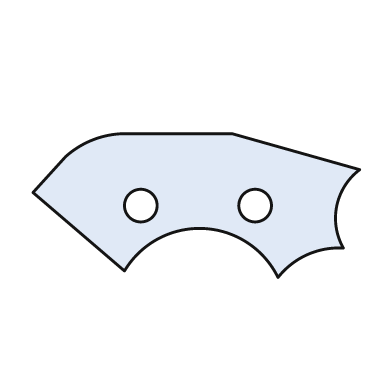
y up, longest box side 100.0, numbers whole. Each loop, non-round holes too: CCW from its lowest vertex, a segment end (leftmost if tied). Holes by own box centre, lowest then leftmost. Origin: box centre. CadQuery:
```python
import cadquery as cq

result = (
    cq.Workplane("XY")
    .moveTo(25.0, -22.0)
    .threePointArc((34.0, -15.0), (45.0, -13.0))
    .threePointArc((43.0, 0.0), (50.0, 11.0))
    .lineTo(11.0, 22.0)
    .lineTo(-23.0, 22.0)
    .threePointArc((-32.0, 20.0), (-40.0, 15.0))
    .lineTo(-50.0, 4.0)
    .lineTo(-22.0, -20.0)
    .threePointArc((2.0, -7.0), (25.0, -22.0))
    .close()
    .moveTo(-17.0, 0.0)
    .circle(5.0)
    .moveTo(18.0, 0.0)
    .circle(5.0)
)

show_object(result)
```